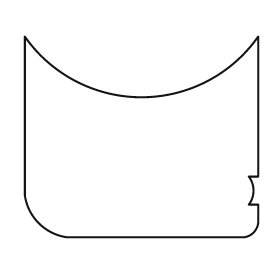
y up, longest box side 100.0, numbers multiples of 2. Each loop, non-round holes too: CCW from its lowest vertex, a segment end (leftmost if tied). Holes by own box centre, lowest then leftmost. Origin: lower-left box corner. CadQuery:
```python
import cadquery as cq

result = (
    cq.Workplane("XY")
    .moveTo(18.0, 0.0)
    .lineTo(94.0, 0.0)
    .threePointArc((98.0, 2.0), (100.0, 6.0))
    .lineTo(100.0, 14.0)
    .lineTo(96.0, 14.0)
    .threePointArc((98.0, 20.0), (96.0, 26.0))
    .lineTo(100.0, 26.0)
    .lineTo(100.0, 86.0)
    .threePointArc((50.0, 60.0), (0.0, 86.0))
    .lineTo(0.0, 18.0)
    .threePointArc((6.0, 6.0), (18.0, 0.0))
    .close()
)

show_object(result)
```